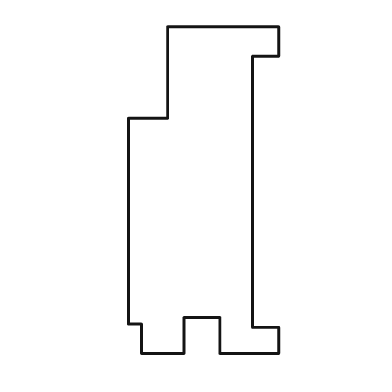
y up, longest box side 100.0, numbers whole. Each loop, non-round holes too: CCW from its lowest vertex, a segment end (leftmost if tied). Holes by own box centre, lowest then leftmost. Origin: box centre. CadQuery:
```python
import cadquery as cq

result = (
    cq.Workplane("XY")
    .moveTo(-19.0, -50.0)
    .lineTo(-6.0, -50.0)
    .lineTo(-6.0, -39.0)
    .lineTo(5.0, -39.0)
    .lineTo(5.0, -50.0)
    .lineTo(23.0, -50.0)
    .lineTo(23.0, -42.0)
    .lineTo(15.0, -42.0)
    .lineTo(15.0, 41.0)
    .lineTo(23.0, 41.0)
    .lineTo(23.0, 50.0)
    .lineTo(-11.0, 50.0)
    .lineTo(-11.0, 22.0)
    .lineTo(-23.0, 22.0)
    .lineTo(-23.0, -41.0)
    .lineTo(-19.0, -41.0)
    .close()
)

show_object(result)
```